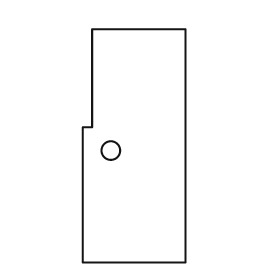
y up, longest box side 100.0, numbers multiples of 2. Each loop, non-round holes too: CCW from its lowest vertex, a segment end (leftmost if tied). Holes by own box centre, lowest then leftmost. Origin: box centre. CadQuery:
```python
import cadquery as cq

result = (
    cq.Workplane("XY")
    .moveTo(-22.0, -50.0)
    .lineTo(22.0, -50.0)
    .lineTo(22.0, 50.0)
    .lineTo(-18.0, 50.0)
    .lineTo(-18.0, 8.0)
    .lineTo(-22.0, 8.0)
    .close()
    .moveTo(-10.0, -2.0)
    .circle(4.0)
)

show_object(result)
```